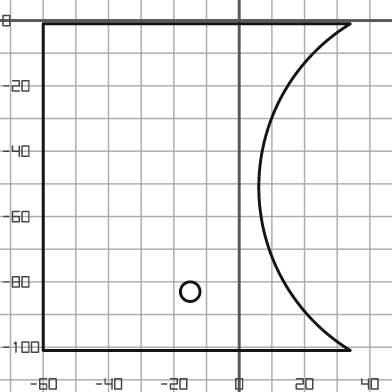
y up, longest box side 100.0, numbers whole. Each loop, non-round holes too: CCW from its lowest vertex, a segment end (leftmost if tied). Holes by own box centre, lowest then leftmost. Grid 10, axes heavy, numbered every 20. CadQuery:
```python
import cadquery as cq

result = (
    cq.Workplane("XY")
    .moveTo(-60.0, -101.0)
    .lineTo(34.0, -101.0)
    .threePointArc((6.0, -51.0), (34.0, -1.0))
    .lineTo(-60.0, -1.0)
    .close()
    .moveTo(-15.0, -83.0)
    .circle(3.0)
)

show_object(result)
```